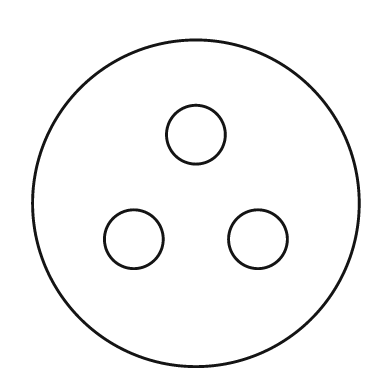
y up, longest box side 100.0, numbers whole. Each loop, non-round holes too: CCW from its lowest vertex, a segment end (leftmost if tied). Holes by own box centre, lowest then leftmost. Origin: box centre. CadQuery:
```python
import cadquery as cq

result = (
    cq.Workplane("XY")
    .moveTo(0.0, 0.0)
    .circle(50.0)
    .moveTo(-19.0, -11.0)
    .circle(9.0)
    .moveTo(19.0, -11.0)
    .circle(9.0)
    .moveTo(0.0, 21.0)
    .circle(9.0)
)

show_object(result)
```